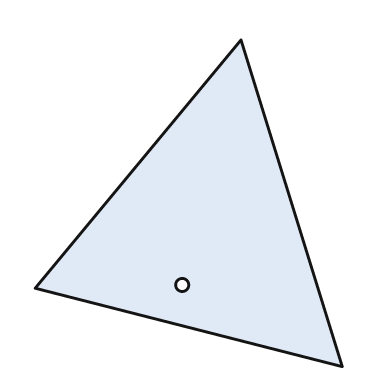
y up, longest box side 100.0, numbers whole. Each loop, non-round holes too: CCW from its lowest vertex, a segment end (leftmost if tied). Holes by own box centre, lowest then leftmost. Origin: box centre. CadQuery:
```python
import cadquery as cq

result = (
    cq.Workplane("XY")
    .moveTo(47.0, -50.0)
    .lineTo(16.0, 50.0)
    .lineTo(-47.0, -26.0)
    .close()
    .moveTo(-2.0, -25.0)
    .circle(2.0)
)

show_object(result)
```